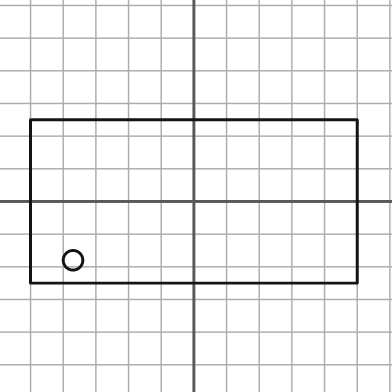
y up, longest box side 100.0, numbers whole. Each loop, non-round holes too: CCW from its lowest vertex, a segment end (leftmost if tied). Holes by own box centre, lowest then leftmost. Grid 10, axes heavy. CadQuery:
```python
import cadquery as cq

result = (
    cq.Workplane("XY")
    .moveTo(-50.0, -25.0)
    .lineTo(50.0, -25.0)
    .lineTo(50.0, 25.0)
    .lineTo(-50.0, 25.0)
    .close()
    .moveTo(-37.0, -18.0)
    .circle(3.0)
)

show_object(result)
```